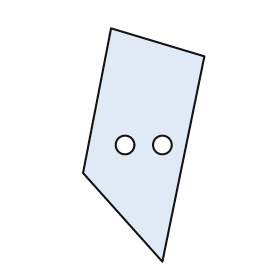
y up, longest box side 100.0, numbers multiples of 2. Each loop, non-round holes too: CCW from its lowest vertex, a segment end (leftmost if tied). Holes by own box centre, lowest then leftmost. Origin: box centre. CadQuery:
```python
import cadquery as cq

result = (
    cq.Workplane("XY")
    .moveTo(8.0, -50.0)
    .lineTo(26.0, 38.0)
    .lineTo(-14.0, 50.0)
    .lineTo(-26.0, -12.0)
    .close()
    .moveTo(-8.0, 0.0)
    .circle(4.0)
    .moveTo(8.0, 0.0)
    .circle(4.0)
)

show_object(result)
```